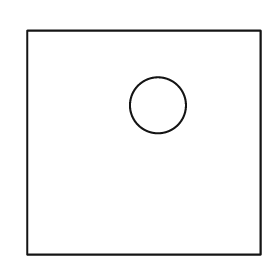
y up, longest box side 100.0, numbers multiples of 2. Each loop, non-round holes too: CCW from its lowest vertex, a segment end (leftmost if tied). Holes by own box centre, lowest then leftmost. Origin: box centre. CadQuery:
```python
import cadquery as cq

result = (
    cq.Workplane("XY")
    .moveTo(-50.0, -48.0)
    .lineTo(50.0, -48.0)
    .lineTo(50.0, 48.0)
    .lineTo(-50.0, 48.0)
    .close()
    .moveTo(6.0, 16.0)
    .circle(12.0)
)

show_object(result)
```